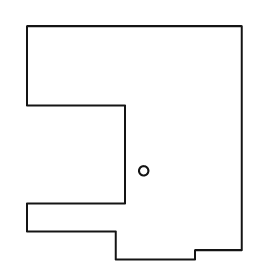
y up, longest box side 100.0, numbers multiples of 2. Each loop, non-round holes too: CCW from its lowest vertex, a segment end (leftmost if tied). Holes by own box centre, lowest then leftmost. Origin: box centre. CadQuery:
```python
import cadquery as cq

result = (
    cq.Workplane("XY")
    .moveTo(-8.0, -50.0)
    .lineTo(26.0, -50.0)
    .lineTo(26.0, -46.0)
    .lineTo(46.0, -46.0)
    .lineTo(46.0, 50.0)
    .lineTo(-46.0, 50.0)
    .lineTo(-46.0, 16.0)
    .lineTo(-4.0, 16.0)
    .lineTo(-4.0, -26.0)
    .lineTo(-46.0, -26.0)
    .lineTo(-46.0, -38.0)
    .lineTo(-8.0, -38.0)
    .close()
    .moveTo(4.0, -12.0)
    .circle(2.0)
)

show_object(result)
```